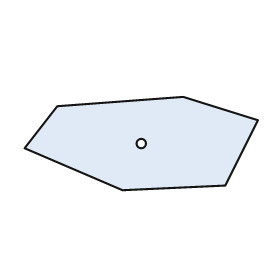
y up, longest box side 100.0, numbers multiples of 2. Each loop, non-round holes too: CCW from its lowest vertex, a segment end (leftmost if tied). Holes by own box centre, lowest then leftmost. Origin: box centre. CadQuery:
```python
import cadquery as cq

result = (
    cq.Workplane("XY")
    .moveTo(-8.0, -20.0)
    .lineTo(36.0, -18.0)
    .lineTo(50.0, 10.0)
    .lineTo(18.0, 20.0)
    .lineTo(-36.0, 16.0)
    .lineTo(-50.0, -2.0)
    .close()
    .moveTo(0.0, 0.0)
    .circle(2.0)
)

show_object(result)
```